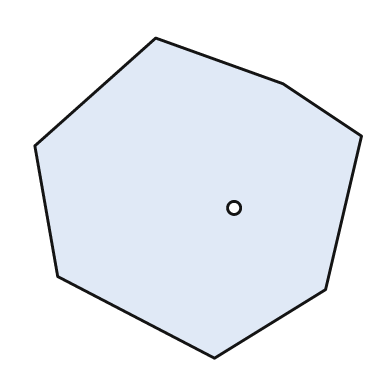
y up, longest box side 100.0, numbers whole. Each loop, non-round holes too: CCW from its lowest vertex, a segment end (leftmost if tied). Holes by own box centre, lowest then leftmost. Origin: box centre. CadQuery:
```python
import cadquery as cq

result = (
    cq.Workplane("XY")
    .moveTo(5.0, -49.0)
    .lineTo(39.0, -28.0)
    .lineTo(50.0, 19.0)
    .lineTo(26.0, 35.0)
    .lineTo(-13.0, 49.0)
    .lineTo(-50.0, 16.0)
    .lineTo(-43.0, -24.0)
    .close()
    .moveTo(11.0, -3.0)
    .circle(2.0)
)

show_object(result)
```